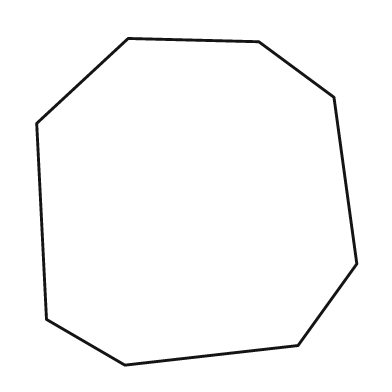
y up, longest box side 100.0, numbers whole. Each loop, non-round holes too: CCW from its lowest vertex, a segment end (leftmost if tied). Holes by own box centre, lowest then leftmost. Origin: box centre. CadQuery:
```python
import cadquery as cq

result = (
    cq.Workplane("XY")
    .moveTo(-22.0, -50.0)
    .lineTo(31.0, -44.0)
    .lineTo(49.0, -19.0)
    .lineTo(42.0, 32.0)
    .lineTo(19.0, 49.0)
    .lineTo(-21.0, 50.0)
    .lineTo(-49.0, 24.0)
    .lineTo(-46.0, -36.0)
    .close()
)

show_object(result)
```